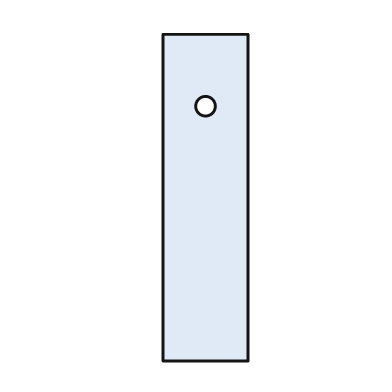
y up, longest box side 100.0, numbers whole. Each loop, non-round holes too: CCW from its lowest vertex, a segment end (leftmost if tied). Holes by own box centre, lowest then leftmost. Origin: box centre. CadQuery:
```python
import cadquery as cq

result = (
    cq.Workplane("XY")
    .moveTo(-13.0, -50.0)
    .lineTo(13.0, -50.0)
    .lineTo(13.0, 50.0)
    .lineTo(-13.0, 50.0)
    .close()
    .moveTo(0.0, 28.0)
    .circle(3.0)
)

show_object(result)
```